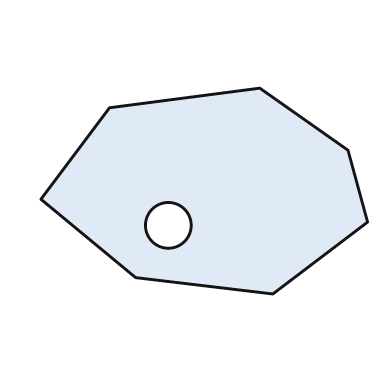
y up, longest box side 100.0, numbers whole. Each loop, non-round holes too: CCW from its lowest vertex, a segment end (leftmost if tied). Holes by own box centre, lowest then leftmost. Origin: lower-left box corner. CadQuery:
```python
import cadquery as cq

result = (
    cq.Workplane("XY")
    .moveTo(71.0, 0.0)
    .lineTo(100.0, 22.0)
    .lineTo(94.0, 44.0)
    .lineTo(67.0, 63.0)
    .lineTo(21.0, 57.0)
    .lineTo(0.0, 29.0)
    .lineTo(29.0, 5.0)
    .close()
    .moveTo(39.0, 21.0)
    .circle(7.0)
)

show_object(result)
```